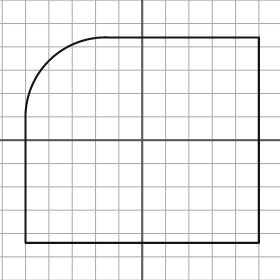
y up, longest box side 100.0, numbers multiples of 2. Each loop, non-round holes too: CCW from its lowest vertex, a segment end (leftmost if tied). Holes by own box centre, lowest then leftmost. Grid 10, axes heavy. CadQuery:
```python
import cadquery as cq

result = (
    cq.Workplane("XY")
    .moveTo(-50.0, -44.0)
    .lineTo(50.0, -44.0)
    .lineTo(50.0, 44.0)
    .lineTo(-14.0, 44.0)
    .threePointArc((-40.0, 34.0), (-50.0, 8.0))
    .close()
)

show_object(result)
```